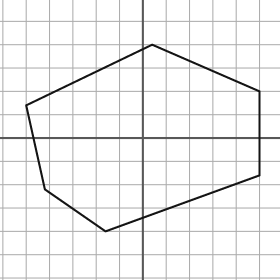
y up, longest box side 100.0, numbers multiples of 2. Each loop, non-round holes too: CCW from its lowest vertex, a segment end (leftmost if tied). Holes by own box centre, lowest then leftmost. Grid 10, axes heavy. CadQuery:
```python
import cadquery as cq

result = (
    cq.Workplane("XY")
    .moveTo(-16.0, -40.0)
    .lineTo(50.0, -16.0)
    .lineTo(50.0, 20.0)
    .lineTo(4.0, 40.0)
    .lineTo(-50.0, 14.0)
    .lineTo(-42.0, -22.0)
    .close()
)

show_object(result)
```